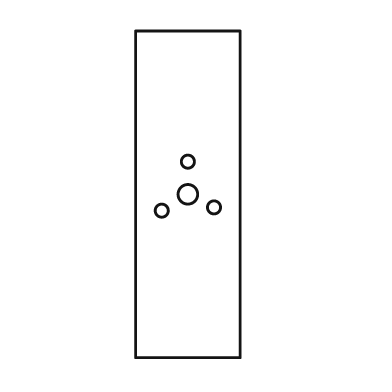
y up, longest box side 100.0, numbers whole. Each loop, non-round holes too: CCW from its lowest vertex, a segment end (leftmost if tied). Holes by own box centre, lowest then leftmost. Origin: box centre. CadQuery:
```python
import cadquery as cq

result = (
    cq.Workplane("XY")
    .moveTo(-16.0, -50.0)
    .lineTo(16.0, -50.0)
    .lineTo(16.0, 50.0)
    .lineTo(-16.0, 50.0)
    .close()
    .moveTo(-8.0, -5.0)
    .circle(2.0)
    .moveTo(8.0, -4.0)
    .circle(2.0)
    .moveTo(0.0, 0.0)
    .circle(3.0)
    .moveTo(0.0, 10.0)
    .circle(2.0)
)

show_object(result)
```